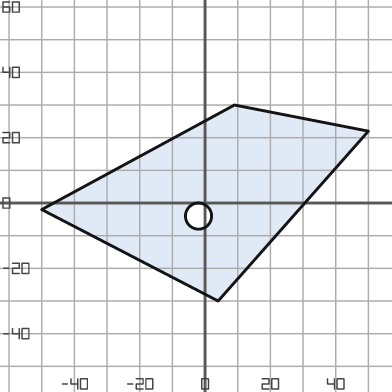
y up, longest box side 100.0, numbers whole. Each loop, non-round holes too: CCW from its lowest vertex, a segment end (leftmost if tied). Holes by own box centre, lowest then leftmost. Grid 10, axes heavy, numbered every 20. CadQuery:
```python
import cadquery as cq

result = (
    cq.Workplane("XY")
    .moveTo(4.0, -30.0)
    .lineTo(50.0, 22.0)
    .lineTo(9.0, 30.0)
    .lineTo(-50.0, -2.0)
    .close()
    .moveTo(-2.0, -4.0)
    .circle(4.0)
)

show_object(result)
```